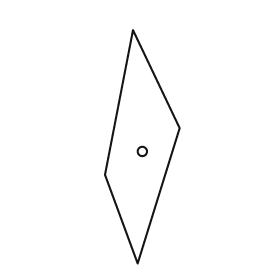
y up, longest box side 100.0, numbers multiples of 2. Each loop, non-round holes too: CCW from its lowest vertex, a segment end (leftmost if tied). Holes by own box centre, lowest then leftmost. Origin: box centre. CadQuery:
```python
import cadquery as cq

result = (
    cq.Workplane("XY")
    .moveTo(-2.0, -50.0)
    .lineTo(16.0, 8.0)
    .lineTo(-4.0, 50.0)
    .lineTo(-16.0, -12.0)
    .close()
    .moveTo(0.0, -2.0)
    .circle(2.0)
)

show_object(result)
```